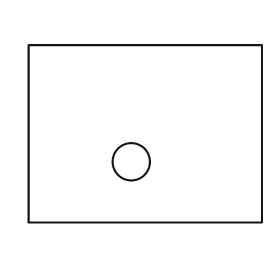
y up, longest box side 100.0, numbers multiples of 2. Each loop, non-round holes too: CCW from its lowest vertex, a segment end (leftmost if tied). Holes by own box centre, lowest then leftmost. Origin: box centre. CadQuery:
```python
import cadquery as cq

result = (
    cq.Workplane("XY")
    .moveTo(-50.0, -38.0)
    .lineTo(50.0, -38.0)
    .lineTo(50.0, 38.0)
    .lineTo(-50.0, 38.0)
    .close()
    .moveTo(-6.0, -12.0)
    .circle(8.0)
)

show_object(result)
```